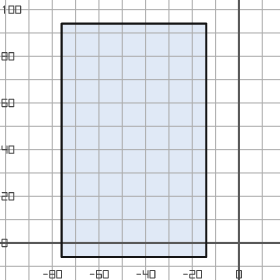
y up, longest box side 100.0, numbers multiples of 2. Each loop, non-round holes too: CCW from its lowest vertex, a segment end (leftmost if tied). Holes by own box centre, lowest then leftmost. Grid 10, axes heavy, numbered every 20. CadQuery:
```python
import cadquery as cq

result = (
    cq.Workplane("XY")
    .moveTo(-76.0, -6.0)
    .lineTo(-14.0, -6.0)
    .lineTo(-14.0, 94.0)
    .lineTo(-76.0, 94.0)
    .close()
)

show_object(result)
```